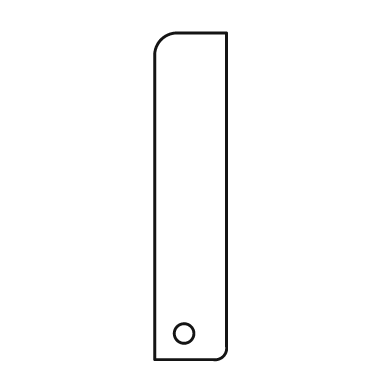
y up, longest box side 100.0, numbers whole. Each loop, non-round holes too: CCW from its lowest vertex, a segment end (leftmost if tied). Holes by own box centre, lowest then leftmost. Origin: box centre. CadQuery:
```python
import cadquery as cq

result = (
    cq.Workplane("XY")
    .moveTo(-11.0, -50.0)
    .lineTo(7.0, -50.0)
    .threePointArc((10.0, -49.0), (11.0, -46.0))
    .lineTo(11.0, 50.0)
    .lineTo(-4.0, 50.0)
    .threePointArc((-9.0, 48.0), (-11.0, 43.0))
    .close()
    .moveTo(-2.0, -42.0)
    .circle(3.0)
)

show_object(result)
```